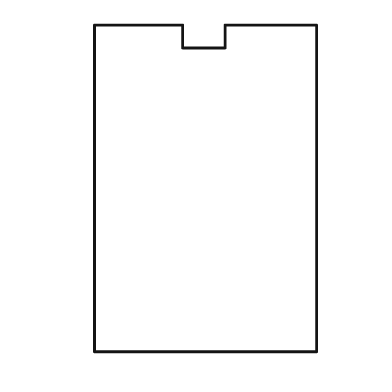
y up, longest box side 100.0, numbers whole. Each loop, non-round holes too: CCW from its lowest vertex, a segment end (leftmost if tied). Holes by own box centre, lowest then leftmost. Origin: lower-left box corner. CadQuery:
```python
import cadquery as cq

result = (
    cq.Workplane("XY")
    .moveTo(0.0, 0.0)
    .lineTo(68.0, 0.0)
    .lineTo(68.0, 100.0)
    .lineTo(40.0, 100.0)
    .lineTo(40.0, 93.0)
    .lineTo(27.0, 93.0)
    .lineTo(27.0, 100.0)
    .lineTo(0.0, 100.0)
    .close()
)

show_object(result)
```